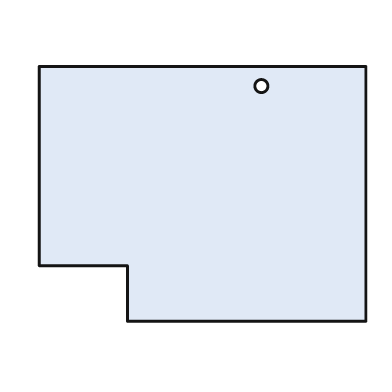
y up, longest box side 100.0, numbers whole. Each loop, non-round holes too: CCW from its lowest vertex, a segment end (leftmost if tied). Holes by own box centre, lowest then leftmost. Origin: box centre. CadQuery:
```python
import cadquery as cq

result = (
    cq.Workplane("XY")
    .moveTo(-23.0, -39.0)
    .lineTo(50.0, -39.0)
    .lineTo(50.0, 39.0)
    .lineTo(-50.0, 39.0)
    .lineTo(-50.0, -22.0)
    .lineTo(-23.0, -22.0)
    .close()
    .moveTo(18.0, 33.0)
    .circle(2.0)
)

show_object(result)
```